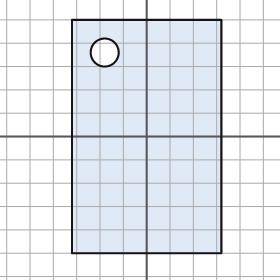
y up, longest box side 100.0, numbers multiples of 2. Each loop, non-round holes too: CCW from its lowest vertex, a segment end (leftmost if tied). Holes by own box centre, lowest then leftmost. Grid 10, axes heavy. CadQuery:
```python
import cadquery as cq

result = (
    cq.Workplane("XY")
    .moveTo(-32.0, -50.0)
    .lineTo(32.0, -50.0)
    .lineTo(32.0, 50.0)
    .lineTo(-32.0, 50.0)
    .close()
    .moveTo(-18.0, 36.0)
    .circle(6.0)
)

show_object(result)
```